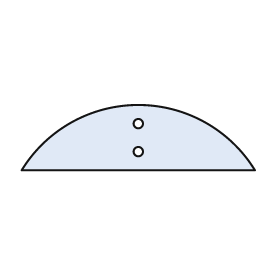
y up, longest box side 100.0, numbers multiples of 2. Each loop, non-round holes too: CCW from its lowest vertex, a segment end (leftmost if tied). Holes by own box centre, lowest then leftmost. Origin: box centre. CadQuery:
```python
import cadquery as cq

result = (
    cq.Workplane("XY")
    .moveTo(-50.0, -14.0)
    .lineTo(50.0, -14.0)
    .threePointArc((0.0, 14.0), (-50.0, -14.0))
    .close()
    .moveTo(0.0, -6.0)
    .circle(2.0)
    .moveTo(0.0, 6.0)
    .circle(2.0)
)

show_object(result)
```